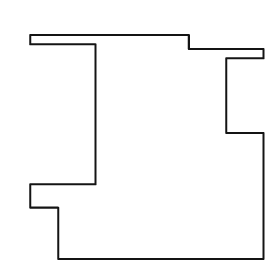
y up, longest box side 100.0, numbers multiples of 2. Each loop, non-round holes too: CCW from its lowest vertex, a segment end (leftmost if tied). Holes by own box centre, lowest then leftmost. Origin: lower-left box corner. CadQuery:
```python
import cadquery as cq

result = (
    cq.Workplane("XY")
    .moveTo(12.0, 0.0)
    .lineTo(100.0, 0.0)
    .lineTo(100.0, 54.0)
    .lineTo(84.0, 54.0)
    .lineTo(84.0, 86.0)
    .lineTo(100.0, 86.0)
    .lineTo(100.0, 90.0)
    .lineTo(68.0, 90.0)
    .lineTo(68.0, 96.0)
    .lineTo(0.0, 96.0)
    .lineTo(0.0, 92.0)
    .lineTo(28.0, 92.0)
    .lineTo(28.0, 32.0)
    .lineTo(0.0, 32.0)
    .lineTo(0.0, 22.0)
    .lineTo(12.0, 22.0)
    .close()
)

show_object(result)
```